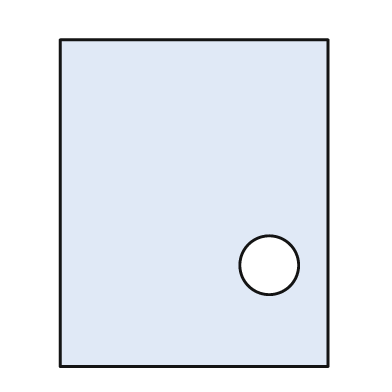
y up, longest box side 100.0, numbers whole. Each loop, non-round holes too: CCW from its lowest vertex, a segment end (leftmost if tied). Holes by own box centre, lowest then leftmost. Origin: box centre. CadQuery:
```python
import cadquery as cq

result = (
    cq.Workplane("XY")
    .moveTo(-41.0, -50.0)
    .lineTo(41.0, -50.0)
    .lineTo(41.0, 50.0)
    .lineTo(-41.0, 50.0)
    .close()
    .moveTo(23.0, -19.0)
    .circle(9.0)
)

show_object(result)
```